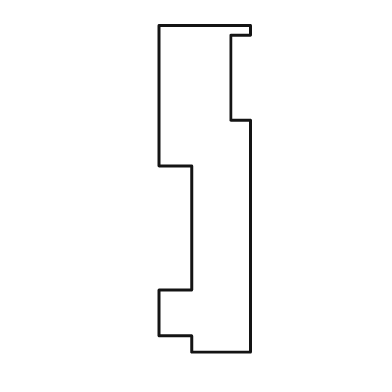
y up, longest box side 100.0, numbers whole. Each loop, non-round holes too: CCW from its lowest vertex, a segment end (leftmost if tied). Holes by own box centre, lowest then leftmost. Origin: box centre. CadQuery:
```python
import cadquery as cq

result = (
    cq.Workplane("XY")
    .moveTo(-4.0, -50.0)
    .lineTo(14.0, -50.0)
    .lineTo(14.0, 21.0)
    .lineTo(8.0, 21.0)
    .lineTo(8.0, 47.0)
    .lineTo(14.0, 47.0)
    .lineTo(14.0, 50.0)
    .lineTo(-14.0, 50.0)
    .lineTo(-14.0, 7.0)
    .lineTo(-4.0, 7.0)
    .lineTo(-4.0, -31.0)
    .lineTo(-14.0, -31.0)
    .lineTo(-14.0, -45.0)
    .lineTo(-4.0, -45.0)
    .close()
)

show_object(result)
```